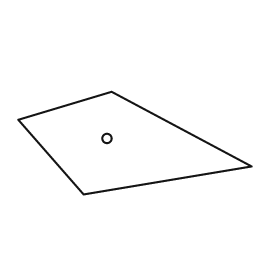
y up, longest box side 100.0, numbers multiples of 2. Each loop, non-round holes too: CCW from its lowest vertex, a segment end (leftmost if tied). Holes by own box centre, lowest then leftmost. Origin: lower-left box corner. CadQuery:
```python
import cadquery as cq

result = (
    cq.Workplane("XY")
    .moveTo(28.0, 0.0)
    .lineTo(100.0, 12.0)
    .lineTo(40.0, 44.0)
    .lineTo(0.0, 32.0)
    .close()
    .moveTo(38.0, 24.0)
    .circle(2.0)
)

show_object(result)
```